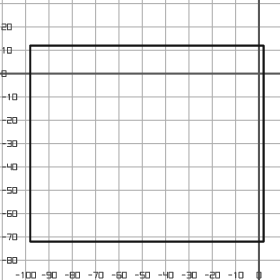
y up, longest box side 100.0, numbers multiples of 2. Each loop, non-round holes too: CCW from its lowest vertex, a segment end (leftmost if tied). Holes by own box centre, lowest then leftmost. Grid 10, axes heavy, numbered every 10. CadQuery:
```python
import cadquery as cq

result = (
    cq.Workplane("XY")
    .moveTo(-98.0, -72.0)
    .lineTo(2.0, -72.0)
    .lineTo(2.0, 12.0)
    .lineTo(-98.0, 12.0)
    .close()
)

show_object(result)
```